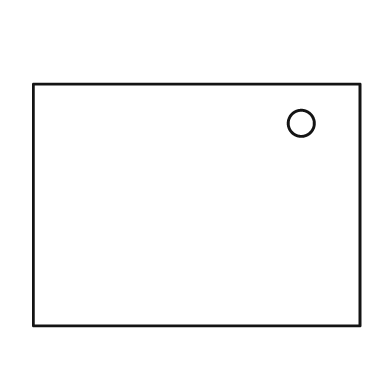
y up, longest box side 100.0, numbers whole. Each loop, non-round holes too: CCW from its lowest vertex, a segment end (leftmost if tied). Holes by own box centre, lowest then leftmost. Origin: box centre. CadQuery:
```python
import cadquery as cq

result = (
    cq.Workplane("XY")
    .moveTo(-50.0, -37.0)
    .lineTo(50.0, -37.0)
    .lineTo(50.0, 37.0)
    .lineTo(-50.0, 37.0)
    .close()
    .moveTo(32.0, 25.0)
    .circle(4.0)
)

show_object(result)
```